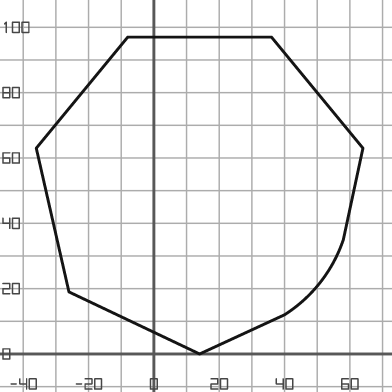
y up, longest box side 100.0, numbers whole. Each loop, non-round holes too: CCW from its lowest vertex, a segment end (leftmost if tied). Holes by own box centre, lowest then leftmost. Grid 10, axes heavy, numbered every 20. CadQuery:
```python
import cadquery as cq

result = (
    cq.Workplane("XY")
    .moveTo(14.0, 0.0)
    .lineTo(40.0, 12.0)
    .threePointArc((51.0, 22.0), (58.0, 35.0))
    .lineTo(64.0, 63.0)
    .lineTo(36.0, 97.0)
    .lineTo(-8.0, 97.0)
    .lineTo(-36.0, 63.0)
    .lineTo(-26.0, 19.0)
    .close()
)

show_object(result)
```